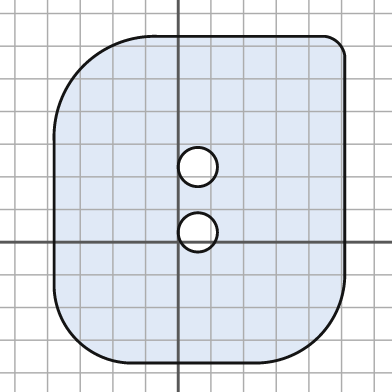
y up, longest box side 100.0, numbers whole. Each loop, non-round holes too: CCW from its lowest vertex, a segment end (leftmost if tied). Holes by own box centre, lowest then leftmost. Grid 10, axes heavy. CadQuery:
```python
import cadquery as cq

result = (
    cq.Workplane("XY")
    .moveTo(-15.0, -37.0)
    .lineTo(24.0, -37.0)
    .threePointArc((43.0, -29.0), (51.0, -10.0))
    .lineTo(51.0, 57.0)
    .threePointArc((49.0, 61.0), (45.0, 63.0))
    .lineTo(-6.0, 63.0)
    .threePointArc((-29.0, 54.0), (-38.0, 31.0))
    .lineTo(-38.0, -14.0)
    .threePointArc((-31.0, -30.0), (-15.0, -37.0))
    .close()
    .moveTo(6.0, 3.0)
    .circle(6.0)
    .moveTo(6.0, 23.0)
    .circle(6.0)
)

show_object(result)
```